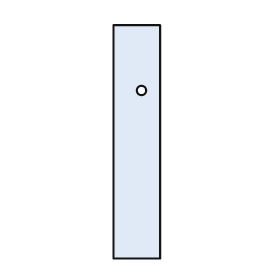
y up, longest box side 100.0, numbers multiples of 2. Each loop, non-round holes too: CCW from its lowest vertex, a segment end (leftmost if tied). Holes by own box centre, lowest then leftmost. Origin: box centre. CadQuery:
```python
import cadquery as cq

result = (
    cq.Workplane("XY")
    .moveTo(-10.0, -50.0)
    .lineTo(10.0, -50.0)
    .lineTo(10.0, 50.0)
    .lineTo(-10.0, 50.0)
    .close()
    .moveTo(2.0, 22.0)
    .circle(2.0)
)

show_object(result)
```